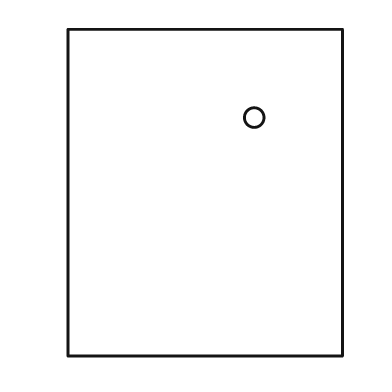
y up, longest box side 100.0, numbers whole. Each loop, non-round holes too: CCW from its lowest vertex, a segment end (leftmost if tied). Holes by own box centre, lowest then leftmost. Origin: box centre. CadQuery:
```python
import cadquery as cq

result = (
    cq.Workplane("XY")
    .moveTo(-42.0, -50.0)
    .lineTo(42.0, -50.0)
    .lineTo(42.0, 50.0)
    .lineTo(-42.0, 50.0)
    .close()
    .moveTo(15.0, 23.0)
    .circle(3.0)
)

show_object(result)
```